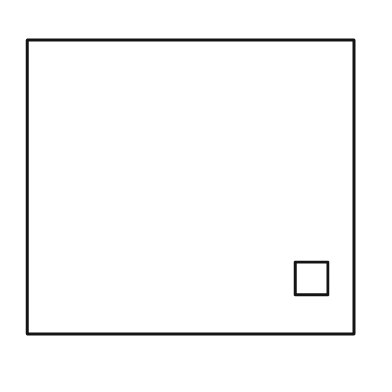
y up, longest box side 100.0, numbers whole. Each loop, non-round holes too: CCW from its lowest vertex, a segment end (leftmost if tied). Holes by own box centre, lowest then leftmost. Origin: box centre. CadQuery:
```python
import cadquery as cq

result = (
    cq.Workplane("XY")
    .moveTo(-50.0, -45.0)
    .lineTo(50.0, -45.0)
    .lineTo(50.0, 45.0)
    .lineTo(-50.0, 45.0)
    .close()
    .moveTo(32.0, -33.0)
    .lineTo(42.0, -33.0)
    .lineTo(42.0, -23.0)
    .lineTo(32.0, -23.0)
    .close()
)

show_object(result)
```